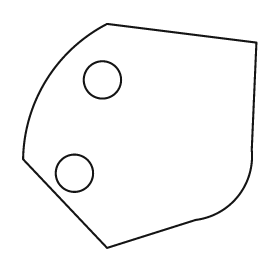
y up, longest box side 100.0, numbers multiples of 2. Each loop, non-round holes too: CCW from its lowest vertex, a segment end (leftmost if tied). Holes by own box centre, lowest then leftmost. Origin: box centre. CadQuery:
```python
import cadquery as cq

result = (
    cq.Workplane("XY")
    .moveTo(-14.0, -48.0)
    .lineTo(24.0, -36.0)
    .threePointArc((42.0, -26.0), (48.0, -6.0))
    .lineTo(50.0, 40.0)
    .lineTo(-14.0, 48.0)
    .threePointArc((-40.0, 24.0), (-50.0, -10.0))
    .close()
    .moveTo(-28.0, -16.0)
    .circle(8.0)
    .moveTo(-16.0, 24.0)
    .circle(8.0)
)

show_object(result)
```